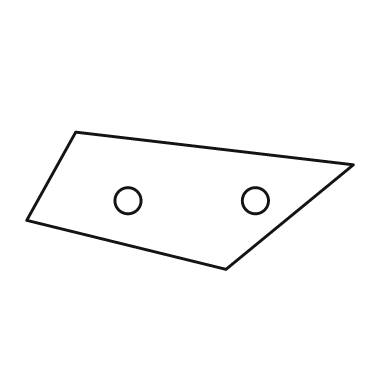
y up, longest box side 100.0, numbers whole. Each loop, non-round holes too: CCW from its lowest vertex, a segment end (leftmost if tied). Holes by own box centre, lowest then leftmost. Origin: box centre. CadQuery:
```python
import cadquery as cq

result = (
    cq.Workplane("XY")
    .moveTo(11.0, -21.0)
    .lineTo(50.0, 11.0)
    .lineTo(-35.0, 21.0)
    .lineTo(-50.0, -6.0)
    .close()
    .moveTo(-19.0, 0.0)
    .circle(4.0)
    .moveTo(20.0, 0.0)
    .circle(4.0)
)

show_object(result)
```